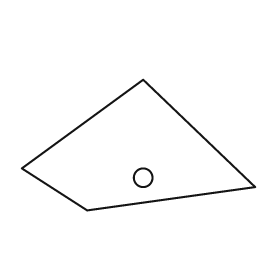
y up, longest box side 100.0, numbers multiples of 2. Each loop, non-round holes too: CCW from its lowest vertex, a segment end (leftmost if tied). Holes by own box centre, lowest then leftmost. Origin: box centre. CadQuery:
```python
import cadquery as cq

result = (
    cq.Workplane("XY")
    .moveTo(-22.0, -28.0)
    .lineTo(50.0, -18.0)
    .lineTo(2.0, 28.0)
    .lineTo(-50.0, -10.0)
    .close()
    .moveTo(2.0, -14.0)
    .circle(4.0)
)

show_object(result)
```